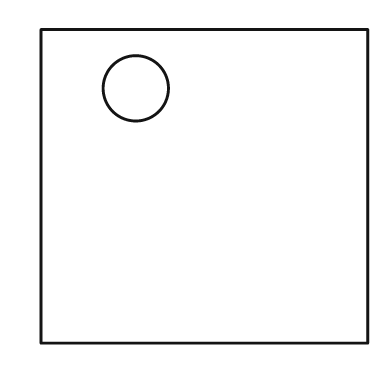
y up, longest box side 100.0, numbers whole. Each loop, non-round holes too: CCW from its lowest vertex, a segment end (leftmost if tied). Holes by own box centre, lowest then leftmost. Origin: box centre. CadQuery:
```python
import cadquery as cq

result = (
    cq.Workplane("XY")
    .moveTo(-50.0, -48.0)
    .lineTo(50.0, -48.0)
    .lineTo(50.0, 48.0)
    .lineTo(-50.0, 48.0)
    .close()
    .moveTo(-21.0, 30.0)
    .circle(10.0)
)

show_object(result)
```